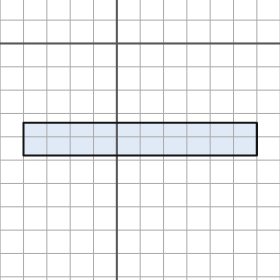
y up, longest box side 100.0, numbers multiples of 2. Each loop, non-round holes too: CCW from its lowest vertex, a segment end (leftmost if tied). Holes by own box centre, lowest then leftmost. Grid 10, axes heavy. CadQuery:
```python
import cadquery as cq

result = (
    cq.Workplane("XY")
    .moveTo(-40.0, -48.0)
    .lineTo(60.0, -48.0)
    .lineTo(60.0, -34.0)
    .lineTo(-40.0, -34.0)
    .close()
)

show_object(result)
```